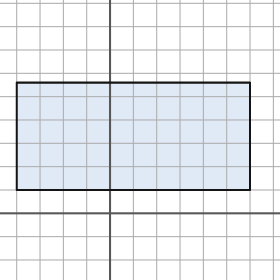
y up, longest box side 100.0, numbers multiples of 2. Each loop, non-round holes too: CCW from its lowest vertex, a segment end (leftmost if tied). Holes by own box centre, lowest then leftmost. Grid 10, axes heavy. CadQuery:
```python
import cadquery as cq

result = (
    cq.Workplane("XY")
    .moveTo(-40.0, 10.0)
    .lineTo(60.0, 10.0)
    .lineTo(60.0, 56.0)
    .lineTo(-40.0, 56.0)
    .close()
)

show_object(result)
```